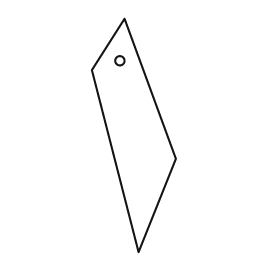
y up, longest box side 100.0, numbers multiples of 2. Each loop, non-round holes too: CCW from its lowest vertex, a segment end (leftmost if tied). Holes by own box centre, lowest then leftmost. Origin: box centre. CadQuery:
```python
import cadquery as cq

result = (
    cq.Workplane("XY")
    .moveTo(2.0, -50.0)
    .lineTo(18.0, -10.0)
    .lineTo(-4.0, 50.0)
    .lineTo(-18.0, 28.0)
    .close()
    .moveTo(-6.0, 32.0)
    .circle(2.0)
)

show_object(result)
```